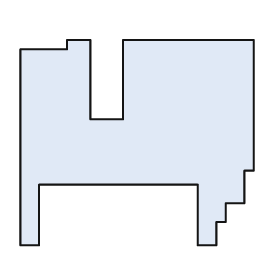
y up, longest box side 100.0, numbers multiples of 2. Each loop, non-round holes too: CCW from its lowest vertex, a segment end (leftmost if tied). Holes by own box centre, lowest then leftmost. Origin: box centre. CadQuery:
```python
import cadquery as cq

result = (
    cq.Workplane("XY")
    .moveTo(-50.0, -44.0)
    .lineTo(-42.0, -44.0)
    .lineTo(-42.0, -18.0)
    .lineTo(26.0, -18.0)
    .lineTo(26.0, -44.0)
    .lineTo(34.0, -44.0)
    .lineTo(34.0, -34.0)
    .lineTo(38.0, -34.0)
    .lineTo(38.0, -26.0)
    .lineTo(46.0, -26.0)
    .lineTo(46.0, -12.0)
    .lineTo(50.0, -12.0)
    .lineTo(50.0, 44.0)
    .lineTo(-6.0, 44.0)
    .lineTo(-6.0, 10.0)
    .lineTo(-20.0, 10.0)
    .lineTo(-20.0, 44.0)
    .lineTo(-30.0, 44.0)
    .lineTo(-30.0, 40.0)
    .lineTo(-50.0, 40.0)
    .close()
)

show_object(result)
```